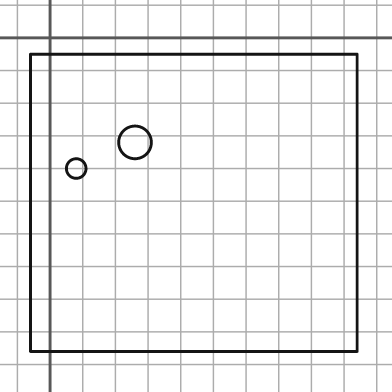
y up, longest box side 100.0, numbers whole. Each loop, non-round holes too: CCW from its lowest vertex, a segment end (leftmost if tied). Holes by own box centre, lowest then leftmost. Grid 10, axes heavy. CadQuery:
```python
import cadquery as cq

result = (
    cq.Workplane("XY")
    .moveTo(-6.0, -96.0)
    .lineTo(94.0, -96.0)
    .lineTo(94.0, -5.0)
    .lineTo(-6.0, -5.0)
    .close()
    .moveTo(8.0, -40.0)
    .circle(3.0)
    .moveTo(26.0, -32.0)
    .circle(5.0)
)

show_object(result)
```